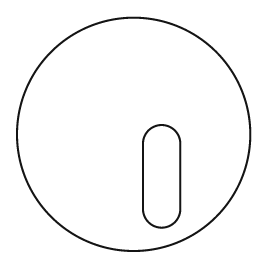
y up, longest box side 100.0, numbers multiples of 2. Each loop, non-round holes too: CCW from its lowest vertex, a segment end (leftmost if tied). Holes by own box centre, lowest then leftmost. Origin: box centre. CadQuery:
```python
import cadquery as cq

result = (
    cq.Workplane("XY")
    .moveTo(0.0, 0.0)
    .circle(50.0)
    .moveTo(4.0, -32.0)
    .threePointArc((12.0, -40.0), (20.0, -32.0))
    .lineTo(20.0, -4.0)
    .threePointArc((12.0, 4.0), (4.0, -4.0))
    .close()
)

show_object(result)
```